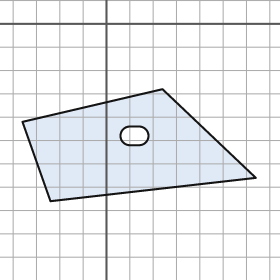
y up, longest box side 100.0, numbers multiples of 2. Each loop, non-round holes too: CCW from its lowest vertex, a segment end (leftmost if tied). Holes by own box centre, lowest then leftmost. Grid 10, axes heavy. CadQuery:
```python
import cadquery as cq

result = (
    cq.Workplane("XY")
    .moveTo(-24.0, -76.0)
    .lineTo(64.0, -66.0)
    .lineTo(24.0, -28.0)
    .lineTo(-36.0, -42.0)
    .close()
    .moveTo(10.0, -52.0)
    .lineTo(14.0, -52.0)
    .threePointArc((18.0, -48.0), (14.0, -44.0))
    .lineTo(10.0, -44.0)
    .threePointArc((6.0, -48.0), (10.0, -52.0))
    .close()
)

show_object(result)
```